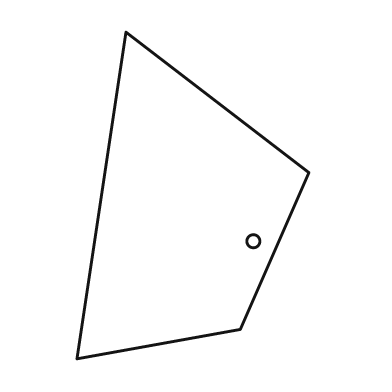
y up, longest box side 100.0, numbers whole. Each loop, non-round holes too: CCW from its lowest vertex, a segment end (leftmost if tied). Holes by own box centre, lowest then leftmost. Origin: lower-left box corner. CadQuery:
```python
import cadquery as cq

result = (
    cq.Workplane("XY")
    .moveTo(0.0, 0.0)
    .lineTo(50.0, 9.0)
    .lineTo(71.0, 57.0)
    .lineTo(15.0, 100.0)
    .close()
    .moveTo(54.0, 36.0)
    .circle(2.0)
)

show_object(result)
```